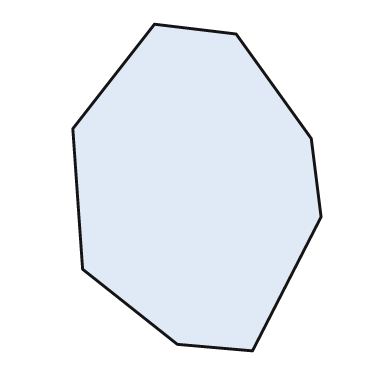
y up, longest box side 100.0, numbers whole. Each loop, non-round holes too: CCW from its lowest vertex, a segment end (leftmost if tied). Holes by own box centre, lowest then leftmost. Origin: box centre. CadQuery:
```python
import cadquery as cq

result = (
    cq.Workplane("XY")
    .moveTo(17.0, -50.0)
    .lineTo(38.0, -9.0)
    .lineTo(35.0, 15.0)
    .lineTo(12.0, 47.0)
    .lineTo(-13.0, 50.0)
    .lineTo(-38.0, 18.0)
    .lineTo(-35.0, -25.0)
    .lineTo(-6.0, -48.0)
    .close()
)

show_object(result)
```